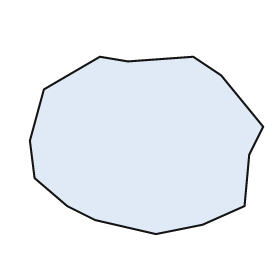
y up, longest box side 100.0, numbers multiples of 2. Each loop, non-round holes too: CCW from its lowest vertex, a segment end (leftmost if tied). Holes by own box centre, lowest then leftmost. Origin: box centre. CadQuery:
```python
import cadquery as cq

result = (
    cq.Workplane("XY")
    .moveTo(4.0, -38.0)
    .lineTo(24.0, -34.0)
    .lineTo(42.0, -26.0)
    .lineTo(44.0, -4.0)
    .lineTo(50.0, 8.0)
    .lineTo(32.0, 30.0)
    .lineTo(20.0, 38.0)
    .lineTo(-8.0, 36.0)
    .lineTo(-20.0, 38.0)
    .lineTo(-44.0, 24.0)
    .lineTo(-50.0, 2.0)
    .lineTo(-48.0, -14.0)
    .lineTo(-34.0, -26.0)
    .lineTo(-22.0, -32.0)
    .close()
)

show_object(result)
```